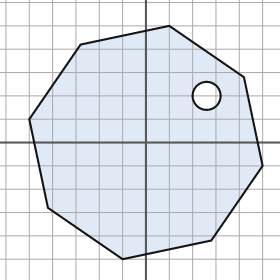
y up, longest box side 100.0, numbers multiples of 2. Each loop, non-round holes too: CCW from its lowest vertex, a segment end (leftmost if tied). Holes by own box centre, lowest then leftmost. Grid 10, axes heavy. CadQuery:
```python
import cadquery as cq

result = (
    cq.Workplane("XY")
    .moveTo(-10.0, -50.0)
    .lineTo(28.0, -42.0)
    .lineTo(50.0, -10.0)
    .lineTo(42.0, 28.0)
    .lineTo(10.0, 50.0)
    .lineTo(-28.0, 42.0)
    .lineTo(-50.0, 10.0)
    .lineTo(-42.0, -28.0)
    .close()
    .moveTo(26.0, 20.0)
    .circle(6.0)
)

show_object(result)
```